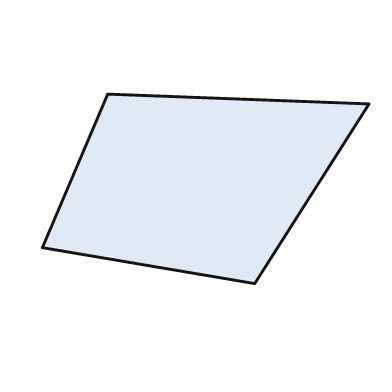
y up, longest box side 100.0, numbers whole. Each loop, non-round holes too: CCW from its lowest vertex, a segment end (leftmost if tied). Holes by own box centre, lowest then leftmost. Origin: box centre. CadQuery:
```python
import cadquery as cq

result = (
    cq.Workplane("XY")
    .moveTo(15.0, -29.0)
    .lineTo(50.0, 26.0)
    .lineTo(-30.0, 29.0)
    .lineTo(-50.0, -18.0)
    .close()
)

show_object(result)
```